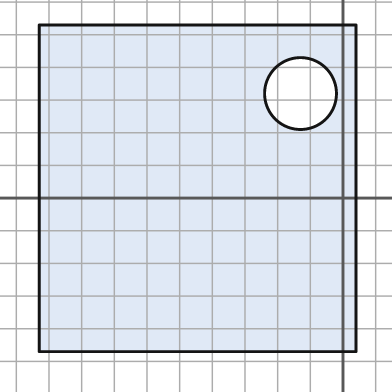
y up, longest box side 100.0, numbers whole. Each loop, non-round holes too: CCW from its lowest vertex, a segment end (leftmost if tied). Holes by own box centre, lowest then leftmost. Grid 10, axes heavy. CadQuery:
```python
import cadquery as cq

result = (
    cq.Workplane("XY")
    .moveTo(-93.0, -47.0)
    .lineTo(4.0, -47.0)
    .lineTo(4.0, 53.0)
    .lineTo(-93.0, 53.0)
    .close()
    .moveTo(-13.0, 32.0)
    .circle(11.0)
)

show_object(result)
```